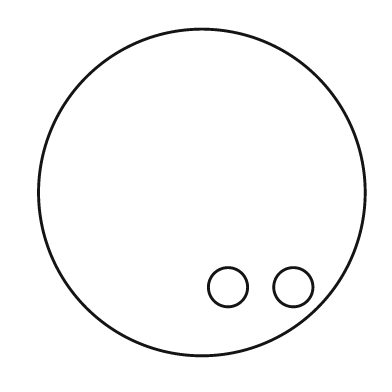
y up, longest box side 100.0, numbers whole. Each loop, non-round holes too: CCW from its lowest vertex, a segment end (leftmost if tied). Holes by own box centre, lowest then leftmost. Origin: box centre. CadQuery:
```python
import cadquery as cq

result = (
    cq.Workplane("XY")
    .moveTo(0.0, 0.0)
    .circle(50.0)
    .moveTo(8.0, -29.0)
    .circle(6.0)
    .moveTo(28.0, -29.0)
    .circle(6.0)
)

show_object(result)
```